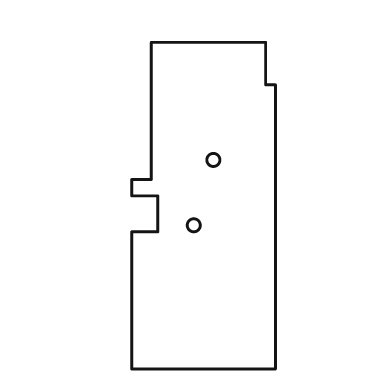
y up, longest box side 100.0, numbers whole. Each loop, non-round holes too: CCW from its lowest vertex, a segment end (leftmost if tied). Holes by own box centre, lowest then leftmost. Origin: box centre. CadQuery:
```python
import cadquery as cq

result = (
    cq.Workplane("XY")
    .moveTo(-22.0, -50.0)
    .lineTo(22.0, -50.0)
    .lineTo(22.0, 37.0)
    .lineTo(19.0, 37.0)
    .lineTo(19.0, 50.0)
    .lineTo(-16.0, 50.0)
    .lineTo(-16.0, 8.0)
    .lineTo(-22.0, 8.0)
    .lineTo(-22.0, 3.0)
    .lineTo(-14.0, 3.0)
    .lineTo(-14.0, -8.0)
    .lineTo(-22.0, -8.0)
    .close()
    .moveTo(-3.0, -6.0)
    .circle(2.0)
    .moveTo(3.0, 14.0)
    .circle(2.0)
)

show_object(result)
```